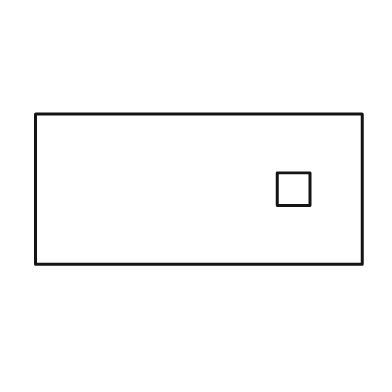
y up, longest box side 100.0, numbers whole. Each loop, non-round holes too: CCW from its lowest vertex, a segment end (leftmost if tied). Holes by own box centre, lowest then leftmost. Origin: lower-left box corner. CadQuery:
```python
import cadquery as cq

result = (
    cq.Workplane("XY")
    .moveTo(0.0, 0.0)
    .lineTo(100.0, 0.0)
    .lineTo(100.0, 46.0)
    .lineTo(0.0, 46.0)
    .close()
    .moveTo(74.0, 18.0)
    .lineTo(84.0, 18.0)
    .lineTo(84.0, 28.0)
    .lineTo(74.0, 28.0)
    .close()
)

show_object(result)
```